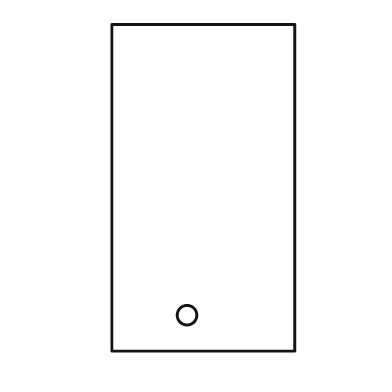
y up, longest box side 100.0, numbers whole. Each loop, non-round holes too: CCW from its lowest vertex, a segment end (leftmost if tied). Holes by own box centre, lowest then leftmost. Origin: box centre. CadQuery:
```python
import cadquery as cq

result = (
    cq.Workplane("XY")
    .moveTo(-28.0, -50.0)
    .lineTo(28.0, -50.0)
    .lineTo(28.0, 50.0)
    .lineTo(-28.0, 50.0)
    .close()
    .moveTo(-5.0, -39.0)
    .circle(3.0)
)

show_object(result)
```